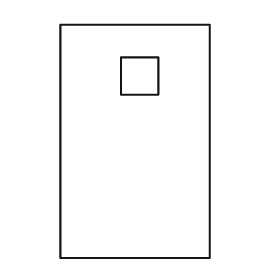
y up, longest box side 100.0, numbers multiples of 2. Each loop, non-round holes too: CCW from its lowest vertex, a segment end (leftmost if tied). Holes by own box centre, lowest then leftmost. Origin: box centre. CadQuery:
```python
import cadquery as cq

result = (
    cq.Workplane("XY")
    .moveTo(-32.0, -50.0)
    .lineTo(32.0, -50.0)
    .lineTo(32.0, 50.0)
    .lineTo(-32.0, 50.0)
    .close()
    .moveTo(-6.0, 20.0)
    .lineTo(10.0, 20.0)
    .lineTo(10.0, 36.0)
    .lineTo(-6.0, 36.0)
    .close()
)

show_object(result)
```